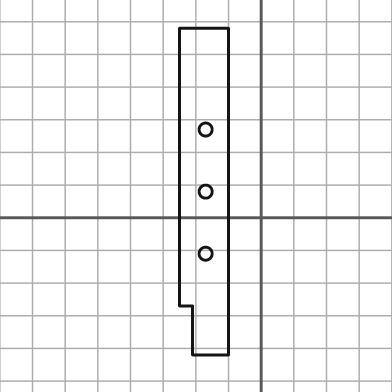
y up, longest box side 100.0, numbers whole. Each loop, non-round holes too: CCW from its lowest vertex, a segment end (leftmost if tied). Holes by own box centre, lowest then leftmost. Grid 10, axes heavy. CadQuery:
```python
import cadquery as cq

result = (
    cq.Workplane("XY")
    .moveTo(-21.0, -42.0)
    .lineTo(-10.0, -42.0)
    .lineTo(-10.0, 58.0)
    .lineTo(-25.0, 58.0)
    .lineTo(-25.0, -27.0)
    .lineTo(-21.0, -27.0)
    .close()
    .moveTo(-17.0, -11.0)
    .circle(2.0)
    .moveTo(-17.0, 8.0)
    .circle(2.0)
    .moveTo(-17.0, 27.0)
    .circle(2.0)
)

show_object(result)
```